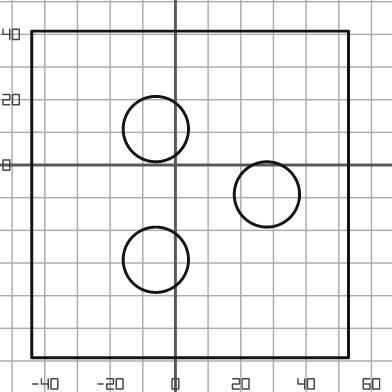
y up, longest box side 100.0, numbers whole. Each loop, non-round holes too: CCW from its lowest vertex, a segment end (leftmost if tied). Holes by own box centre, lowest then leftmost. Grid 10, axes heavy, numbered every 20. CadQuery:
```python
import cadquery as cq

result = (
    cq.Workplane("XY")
    .moveTo(-44.0, -59.0)
    .lineTo(53.0, -59.0)
    .lineTo(53.0, 41.0)
    .lineTo(-44.0, 41.0)
    .close()
    .moveTo(-6.0, -29.0)
    .circle(10.0)
    .moveTo(28.0, -9.0)
    .circle(10.0)
    .moveTo(-6.0, 11.0)
    .circle(10.0)
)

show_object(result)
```